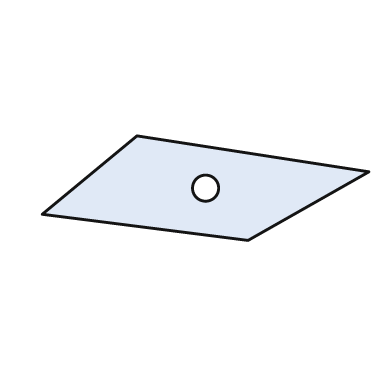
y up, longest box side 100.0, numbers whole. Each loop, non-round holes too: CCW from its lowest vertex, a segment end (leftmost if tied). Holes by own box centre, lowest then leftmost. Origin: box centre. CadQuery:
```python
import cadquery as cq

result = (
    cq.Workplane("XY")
    .moveTo(13.0, -16.0)
    .lineTo(50.0, 5.0)
    .lineTo(-21.0, 16.0)
    .lineTo(-50.0, -8.0)
    .close()
    .moveTo(0.0, 0.0)
    .circle(4.0)
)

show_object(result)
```